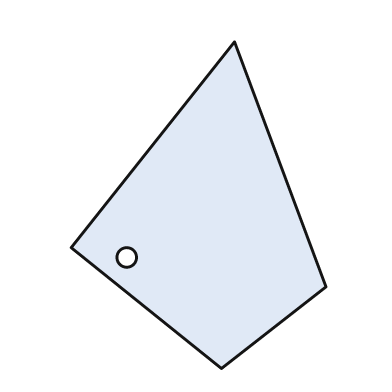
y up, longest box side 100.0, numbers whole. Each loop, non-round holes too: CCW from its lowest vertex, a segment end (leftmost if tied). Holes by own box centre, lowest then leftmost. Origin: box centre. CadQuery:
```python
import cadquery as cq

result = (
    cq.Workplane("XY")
    .moveTo(7.0, -50.0)
    .lineTo(39.0, -25.0)
    .lineTo(11.0, 50.0)
    .lineTo(-39.0, -13.0)
    .close()
    .moveTo(-22.0, -16.0)
    .circle(3.0)
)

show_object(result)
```